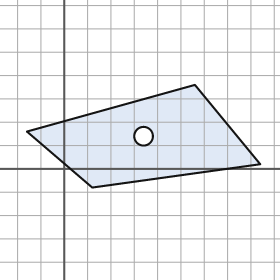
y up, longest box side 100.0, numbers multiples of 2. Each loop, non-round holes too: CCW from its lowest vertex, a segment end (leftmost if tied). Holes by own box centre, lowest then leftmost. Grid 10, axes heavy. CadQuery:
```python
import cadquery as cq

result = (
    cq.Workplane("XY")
    .moveTo(12.0, -8.0)
    .lineTo(84.0, 2.0)
    .lineTo(56.0, 36.0)
    .lineTo(-16.0, 16.0)
    .close()
    .moveTo(34.0, 14.0)
    .circle(4.0)
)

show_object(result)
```